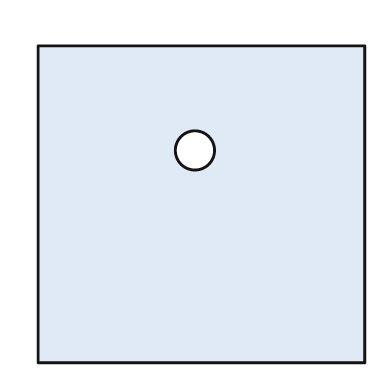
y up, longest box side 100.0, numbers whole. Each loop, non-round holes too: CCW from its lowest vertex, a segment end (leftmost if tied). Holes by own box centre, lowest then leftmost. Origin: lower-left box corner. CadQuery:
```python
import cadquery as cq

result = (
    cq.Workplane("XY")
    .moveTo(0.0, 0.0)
    .lineTo(100.0, 0.0)
    .lineTo(100.0, 97.0)
    .lineTo(0.0, 97.0)
    .close()
    .moveTo(48.0, 65.0)
    .circle(6.0)
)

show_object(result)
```